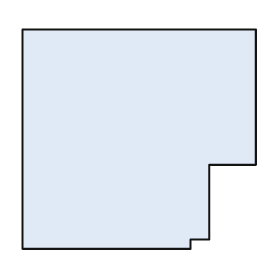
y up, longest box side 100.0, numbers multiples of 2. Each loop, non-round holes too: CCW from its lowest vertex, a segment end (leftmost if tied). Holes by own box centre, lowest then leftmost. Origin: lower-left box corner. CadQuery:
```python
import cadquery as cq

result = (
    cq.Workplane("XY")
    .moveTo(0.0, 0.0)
    .lineTo(72.0, 0.0)
    .lineTo(72.0, 4.0)
    .lineTo(80.0, 4.0)
    .lineTo(80.0, 36.0)
    .lineTo(100.0, 36.0)
    .lineTo(100.0, 94.0)
    .lineTo(0.0, 94.0)
    .close()
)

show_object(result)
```